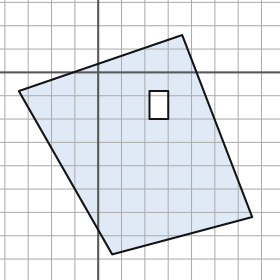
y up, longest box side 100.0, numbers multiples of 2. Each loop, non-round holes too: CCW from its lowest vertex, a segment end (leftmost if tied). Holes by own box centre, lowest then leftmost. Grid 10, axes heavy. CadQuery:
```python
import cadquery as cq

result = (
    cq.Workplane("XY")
    .moveTo(6.0, -78.0)
    .lineTo(66.0, -62.0)
    .lineTo(36.0, 16.0)
    .lineTo(-34.0, -8.0)
    .close()
    .moveTo(22.0, -20.0)
    .lineTo(30.0, -20.0)
    .lineTo(30.0, -8.0)
    .lineTo(22.0, -8.0)
    .close()
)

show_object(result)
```